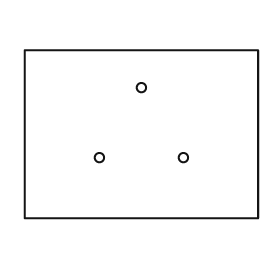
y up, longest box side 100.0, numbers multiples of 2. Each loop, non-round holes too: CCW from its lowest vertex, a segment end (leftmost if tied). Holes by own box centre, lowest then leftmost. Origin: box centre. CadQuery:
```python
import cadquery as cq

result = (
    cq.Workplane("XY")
    .moveTo(-50.0, -36.0)
    .lineTo(50.0, -36.0)
    .lineTo(50.0, 36.0)
    .lineTo(-50.0, 36.0)
    .close()
    .moveTo(-18.0, -10.0)
    .circle(2.0)
    .moveTo(18.0, -10.0)
    .circle(2.0)
    .moveTo(0.0, 20.0)
    .circle(2.0)
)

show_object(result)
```